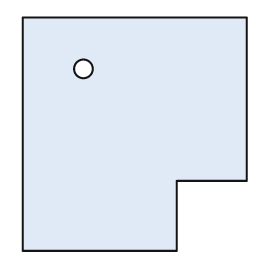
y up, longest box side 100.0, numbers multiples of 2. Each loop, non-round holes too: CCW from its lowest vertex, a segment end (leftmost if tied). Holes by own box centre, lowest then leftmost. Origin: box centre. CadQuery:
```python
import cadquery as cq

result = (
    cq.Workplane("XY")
    .moveTo(-48.0, -50.0)
    .lineTo(18.0, -50.0)
    .lineTo(18.0, -20.0)
    .lineTo(48.0, -20.0)
    .lineTo(48.0, 50.0)
    .lineTo(-48.0, 50.0)
    .close()
    .moveTo(-22.0, 28.0)
    .circle(4.0)
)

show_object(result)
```